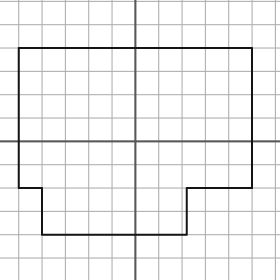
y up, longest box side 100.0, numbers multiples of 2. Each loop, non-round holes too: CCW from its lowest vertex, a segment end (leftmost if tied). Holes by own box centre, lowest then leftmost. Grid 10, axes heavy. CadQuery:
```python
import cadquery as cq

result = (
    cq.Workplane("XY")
    .moveTo(-40.0, -40.0)
    .lineTo(22.0, -40.0)
    .lineTo(22.0, -20.0)
    .lineTo(50.0, -20.0)
    .lineTo(50.0, 40.0)
    .lineTo(-50.0, 40.0)
    .lineTo(-50.0, -20.0)
    .lineTo(-40.0, -20.0)
    .close()
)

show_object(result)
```